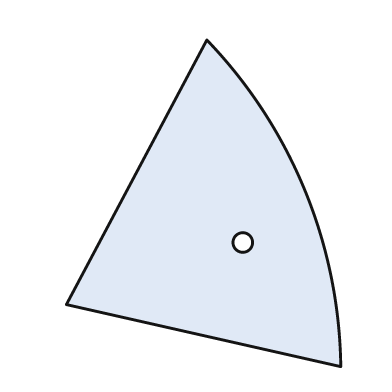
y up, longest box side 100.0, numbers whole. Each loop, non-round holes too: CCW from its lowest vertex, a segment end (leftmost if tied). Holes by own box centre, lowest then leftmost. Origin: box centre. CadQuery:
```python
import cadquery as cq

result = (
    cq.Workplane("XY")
    .moveTo(42.0, -50.0)
    .threePointArc((31.0, 4.0), (1.0, 50.0))
    .lineTo(-42.0, -31.0)
    .close()
    .moveTo(12.0, -12.0)
    .circle(3.0)
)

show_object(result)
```